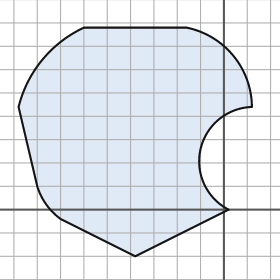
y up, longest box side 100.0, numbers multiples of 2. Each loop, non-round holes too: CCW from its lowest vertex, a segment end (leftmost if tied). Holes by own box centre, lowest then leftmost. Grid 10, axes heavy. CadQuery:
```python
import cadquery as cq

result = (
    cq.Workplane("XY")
    .moveTo(-38.0, -20.0)
    .lineTo(2.0, 0.0)
    .threePointArc((-10.0, 26.0), (12.0, 44.0))
    .threePointArc((4.0, 66.0), (-16.0, 78.0))
    .lineTo(-60.0, 78.0)
    .threePointArc((-78.0, 64.0), (-88.0, 44.0))
    .lineTo(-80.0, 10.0)
    .threePointArc((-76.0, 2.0), (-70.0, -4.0))
    .close()
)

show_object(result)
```